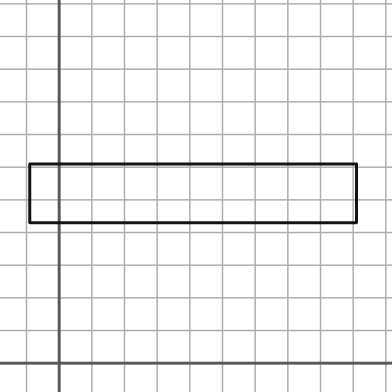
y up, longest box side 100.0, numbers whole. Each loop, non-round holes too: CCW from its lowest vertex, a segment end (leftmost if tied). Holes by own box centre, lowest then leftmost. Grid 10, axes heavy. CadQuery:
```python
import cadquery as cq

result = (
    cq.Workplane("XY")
    .moveTo(-9.0, 43.0)
    .lineTo(91.0, 43.0)
    .lineTo(91.0, 61.0)
    .lineTo(-9.0, 61.0)
    .close()
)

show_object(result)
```